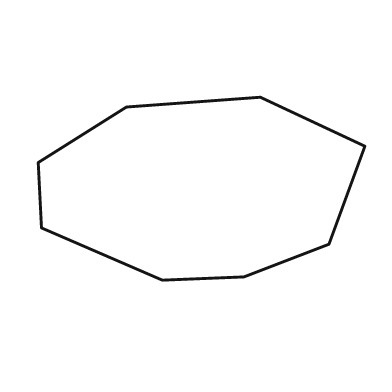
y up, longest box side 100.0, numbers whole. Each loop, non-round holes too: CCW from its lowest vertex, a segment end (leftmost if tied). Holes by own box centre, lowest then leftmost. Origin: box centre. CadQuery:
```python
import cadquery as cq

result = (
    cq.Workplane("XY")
    .moveTo(-12.0, -28.0)
    .lineTo(13.0, -27.0)
    .lineTo(39.0, -17.0)
    .lineTo(50.0, 13.0)
    .lineTo(18.0, 28.0)
    .lineTo(-23.0, 25.0)
    .lineTo(-50.0, 8.0)
    .lineTo(-49.0, -12.0)
    .close()
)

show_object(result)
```